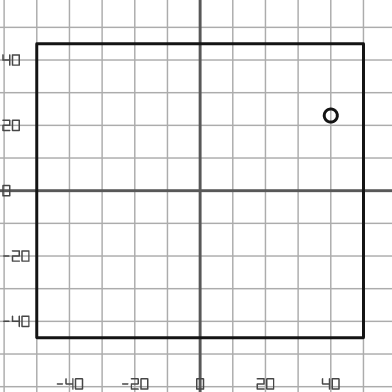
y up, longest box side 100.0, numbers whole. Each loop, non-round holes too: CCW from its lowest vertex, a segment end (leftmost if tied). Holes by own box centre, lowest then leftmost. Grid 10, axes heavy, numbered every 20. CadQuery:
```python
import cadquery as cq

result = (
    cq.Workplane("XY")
    .moveTo(-50.0, -45.0)
    .lineTo(50.0, -45.0)
    .lineTo(50.0, 45.0)
    .lineTo(-50.0, 45.0)
    .close()
    .moveTo(40.0, 23.0)
    .circle(2.0)
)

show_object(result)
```